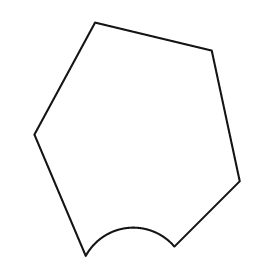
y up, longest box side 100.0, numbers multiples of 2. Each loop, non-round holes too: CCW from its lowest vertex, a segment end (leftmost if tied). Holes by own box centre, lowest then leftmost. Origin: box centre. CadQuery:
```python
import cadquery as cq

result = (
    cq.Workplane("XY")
    .moveTo(-22.0, -50.0)
    .threePointArc((-4.0, -38.0), (16.0, -46.0))
    .lineTo(44.0, -18.0)
    .lineTo(32.0, 38.0)
    .lineTo(-18.0, 50.0)
    .lineTo(-44.0, 2.0)
    .close()
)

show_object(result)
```